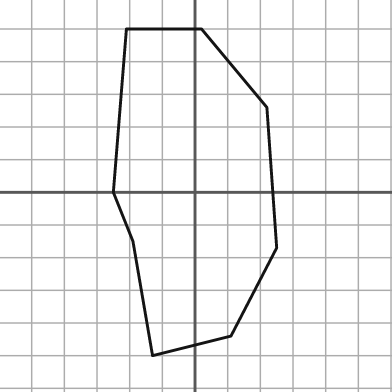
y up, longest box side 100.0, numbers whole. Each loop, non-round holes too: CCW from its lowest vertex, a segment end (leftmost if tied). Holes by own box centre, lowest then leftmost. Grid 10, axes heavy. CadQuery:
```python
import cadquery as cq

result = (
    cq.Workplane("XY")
    .moveTo(-13.0, -50.0)
    .lineTo(11.0, -44.0)
    .lineTo(25.0, -17.0)
    .lineTo(22.0, 26.0)
    .lineTo(2.0, 50.0)
    .lineTo(-21.0, 50.0)
    .lineTo(-25.0, 0.0)
    .lineTo(-19.0, -15.0)
    .close()
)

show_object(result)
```